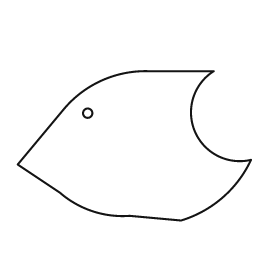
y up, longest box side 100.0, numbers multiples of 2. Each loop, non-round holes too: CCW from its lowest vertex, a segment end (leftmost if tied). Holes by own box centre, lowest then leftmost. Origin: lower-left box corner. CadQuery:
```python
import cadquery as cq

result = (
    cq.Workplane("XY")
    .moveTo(70.0, 0.0)
    .threePointArc((88.0, 10.0), (100.0, 26.0))
    .threePointArc((76.0, 38.0), (84.0, 64.0))
    .lineTo(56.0, 64.0)
    .threePointArc((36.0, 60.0), (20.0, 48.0))
    .lineTo(0.0, 24.0)
    .lineTo(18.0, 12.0)
    .threePointArc((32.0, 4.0), (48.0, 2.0))
    .close()
    .moveTo(30.0, 46.0)
    .circle(2.0)
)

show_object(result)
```